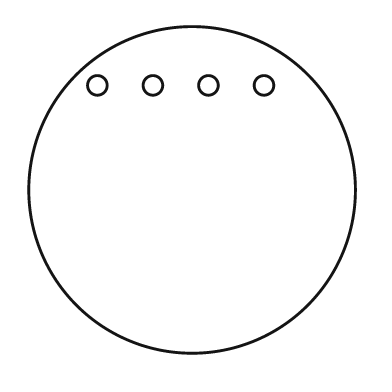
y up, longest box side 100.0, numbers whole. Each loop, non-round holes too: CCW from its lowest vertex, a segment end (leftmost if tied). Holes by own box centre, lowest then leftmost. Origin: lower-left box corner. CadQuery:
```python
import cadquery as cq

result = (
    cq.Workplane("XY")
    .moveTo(50.0, 50.0)
    .circle(50.0)
    .moveTo(21.0, 82.0)
    .circle(3.0)
    .moveTo(38.0, 82.0)
    .circle(3.0)
    .moveTo(55.0, 82.0)
    .circle(3.0)
    .moveTo(72.0, 82.0)
    .circle(3.0)
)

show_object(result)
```